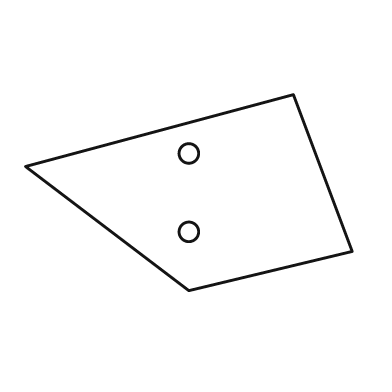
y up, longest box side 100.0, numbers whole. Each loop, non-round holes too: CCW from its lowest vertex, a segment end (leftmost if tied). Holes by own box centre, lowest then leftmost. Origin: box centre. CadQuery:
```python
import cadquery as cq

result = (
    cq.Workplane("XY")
    .moveTo(0.0, -30.0)
    .lineTo(50.0, -18.0)
    .lineTo(32.0, 30.0)
    .lineTo(-50.0, 8.0)
    .close()
    .moveTo(0.0, -12.0)
    .circle(3.0)
    .moveTo(0.0, 12.0)
    .circle(3.0)
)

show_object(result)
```